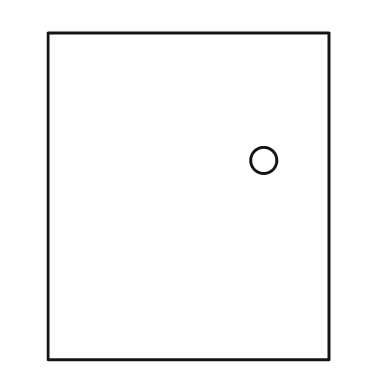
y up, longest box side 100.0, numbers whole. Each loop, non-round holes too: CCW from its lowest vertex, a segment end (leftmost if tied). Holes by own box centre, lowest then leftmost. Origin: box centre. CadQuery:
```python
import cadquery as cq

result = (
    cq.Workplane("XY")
    .moveTo(-43.0, -50.0)
    .lineTo(43.0, -50.0)
    .lineTo(43.0, 50.0)
    .lineTo(-43.0, 50.0)
    .close()
    .moveTo(23.0, 11.0)
    .circle(4.0)
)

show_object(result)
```